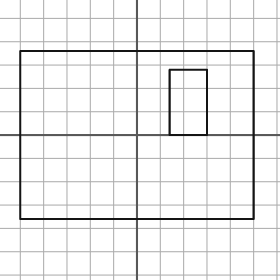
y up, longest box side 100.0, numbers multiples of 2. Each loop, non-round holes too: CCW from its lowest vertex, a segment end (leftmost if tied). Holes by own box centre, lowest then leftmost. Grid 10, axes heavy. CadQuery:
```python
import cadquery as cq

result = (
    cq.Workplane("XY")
    .moveTo(-50.0, -36.0)
    .lineTo(50.0, -36.0)
    .lineTo(50.0, 36.0)
    .lineTo(-50.0, 36.0)
    .close()
    .moveTo(14.0, 0.0)
    .lineTo(30.0, 0.0)
    .lineTo(30.0, 28.0)
    .lineTo(14.0, 28.0)
    .close()
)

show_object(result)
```